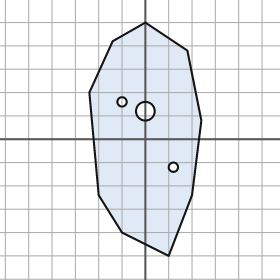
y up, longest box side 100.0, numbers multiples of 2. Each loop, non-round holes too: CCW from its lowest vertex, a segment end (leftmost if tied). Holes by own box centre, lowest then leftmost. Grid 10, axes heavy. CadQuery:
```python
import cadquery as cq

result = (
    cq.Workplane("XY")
    .moveTo(10.0, -50.0)
    .lineTo(20.0, -24.0)
    .lineTo(24.0, 8.0)
    .lineTo(18.0, 38.0)
    .lineTo(0.0, 50.0)
    .lineTo(-14.0, 42.0)
    .lineTo(-24.0, 20.0)
    .lineTo(-20.0, -24.0)
    .lineTo(-10.0, -40.0)
    .close()
    .moveTo(12.0, -12.0)
    .circle(2.0)
    .moveTo(0.0, 12.0)
    .circle(4.0)
    .moveTo(-10.0, 16.0)
    .circle(2.0)
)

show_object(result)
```